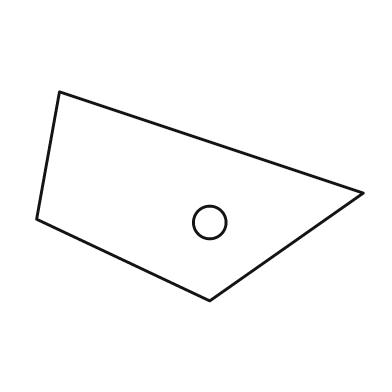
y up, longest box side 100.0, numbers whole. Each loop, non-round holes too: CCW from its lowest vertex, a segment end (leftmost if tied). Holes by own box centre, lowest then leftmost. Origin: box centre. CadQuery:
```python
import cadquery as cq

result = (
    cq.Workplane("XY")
    .moveTo(3.0, -32.0)
    .lineTo(50.0, 1.0)
    .lineTo(-43.0, 32.0)
    .lineTo(-50.0, -7.0)
    .close()
    .moveTo(3.0, -8.0)
    .circle(5.0)
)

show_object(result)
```